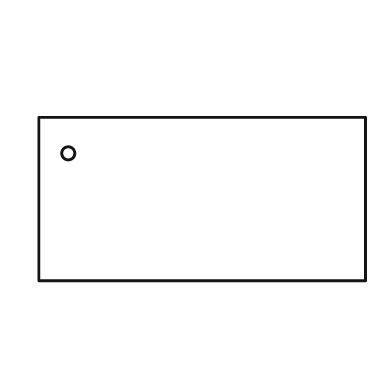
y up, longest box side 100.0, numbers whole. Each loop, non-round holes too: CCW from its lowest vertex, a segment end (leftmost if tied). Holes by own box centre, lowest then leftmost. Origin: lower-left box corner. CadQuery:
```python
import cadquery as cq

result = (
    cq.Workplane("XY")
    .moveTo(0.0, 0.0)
    .lineTo(100.0, 0.0)
    .lineTo(100.0, 50.0)
    .lineTo(0.0, 50.0)
    .close()
    .moveTo(9.0, 39.0)
    .circle(2.0)
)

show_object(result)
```